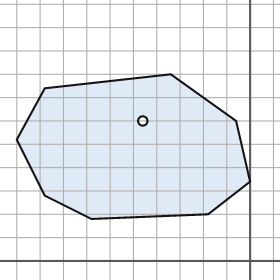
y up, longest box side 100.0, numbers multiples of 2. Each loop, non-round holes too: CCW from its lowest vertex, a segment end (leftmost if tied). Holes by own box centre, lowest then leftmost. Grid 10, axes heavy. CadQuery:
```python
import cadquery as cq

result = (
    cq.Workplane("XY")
    .moveTo(-68.0, 18.0)
    .lineTo(-18.0, 20.0)
    .lineTo(0.0, 34.0)
    .lineTo(-6.0, 60.0)
    .lineTo(-34.0, 80.0)
    .lineTo(-88.0, 74.0)
    .lineTo(-100.0, 52.0)
    .lineTo(-88.0, 28.0)
    .close()
    .moveTo(-46.0, 60.0)
    .circle(2.0)
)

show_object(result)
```